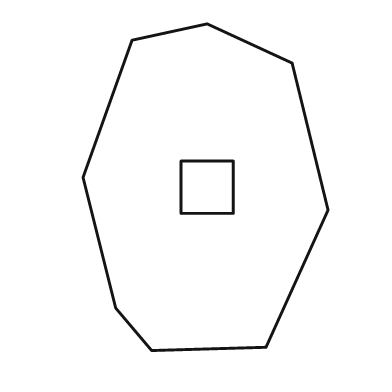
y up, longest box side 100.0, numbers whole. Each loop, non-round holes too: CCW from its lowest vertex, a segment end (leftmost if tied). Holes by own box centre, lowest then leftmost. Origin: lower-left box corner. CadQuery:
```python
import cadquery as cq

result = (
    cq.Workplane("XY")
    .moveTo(21.0, 0.0)
    .lineTo(56.0, 1.0)
    .lineTo(75.0, 43.0)
    .lineTo(64.0, 88.0)
    .lineTo(38.0, 100.0)
    .lineTo(15.0, 95.0)
    .lineTo(0.0, 53.0)
    .lineTo(10.0, 13.0)
    .close()
    .moveTo(30.0, 42.0)
    .lineTo(46.0, 42.0)
    .lineTo(46.0, 58.0)
    .lineTo(30.0, 58.0)
    .close()
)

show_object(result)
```